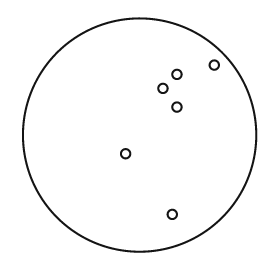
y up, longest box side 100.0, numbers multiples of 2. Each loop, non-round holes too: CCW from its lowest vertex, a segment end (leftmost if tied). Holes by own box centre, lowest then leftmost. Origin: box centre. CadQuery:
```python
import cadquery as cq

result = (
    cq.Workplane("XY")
    .moveTo(0.0, 0.0)
    .circle(50.0)
    .moveTo(14.0, -34.0)
    .circle(2.0)
    .moveTo(-6.0, -8.0)
    .circle(2.0)
    .moveTo(16.0, 12.0)
    .circle(2.0)
    .moveTo(10.0, 20.0)
    .circle(2.0)
    .moveTo(16.0, 26.0)
    .circle(2.0)
    .moveTo(32.0, 30.0)
    .circle(2.0)
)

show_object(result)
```